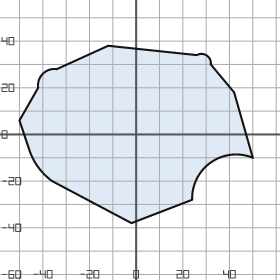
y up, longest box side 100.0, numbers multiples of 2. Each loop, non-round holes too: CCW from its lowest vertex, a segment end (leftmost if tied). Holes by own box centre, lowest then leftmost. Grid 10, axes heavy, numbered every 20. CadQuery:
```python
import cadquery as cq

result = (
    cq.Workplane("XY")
    .moveTo(-2.0, -38.0)
    .lineTo(24.0, -28.0)
    .threePointArc((32.0, -12.0), (50.0, -10.0))
    .lineTo(42.0, 18.0)
    .lineTo(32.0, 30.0)
    .threePointArc((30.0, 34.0), (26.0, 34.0))
    .lineTo(-12.0, 38.0)
    .lineTo(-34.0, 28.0)
    .threePointArc((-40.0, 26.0), (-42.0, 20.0))
    .lineTo(-50.0, 6.0)
    .lineTo(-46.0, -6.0)
    .threePointArc((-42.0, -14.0), (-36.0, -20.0))
    .close()
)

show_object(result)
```